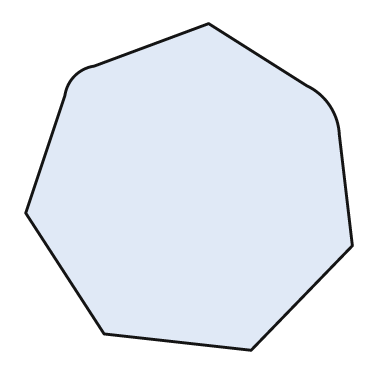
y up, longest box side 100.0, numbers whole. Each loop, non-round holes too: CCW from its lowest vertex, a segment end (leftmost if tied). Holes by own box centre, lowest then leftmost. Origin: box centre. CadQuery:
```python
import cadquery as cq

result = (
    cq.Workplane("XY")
    .moveTo(19.0, -50.0)
    .lineTo(50.0, -18.0)
    .lineTo(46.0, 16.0)
    .threePointArc((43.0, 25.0), (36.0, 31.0))
    .lineTo(6.0, 50.0)
    .lineTo(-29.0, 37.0)
    .threePointArc((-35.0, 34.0), (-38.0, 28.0))
    .lineTo(-50.0, -8.0)
    .lineTo(-26.0, -45.0)
    .close()
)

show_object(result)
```